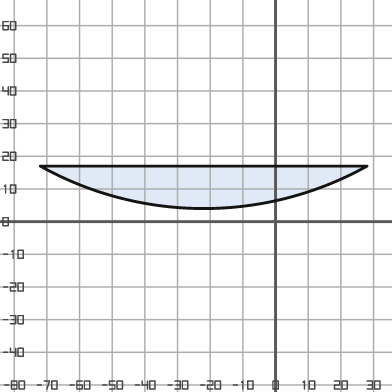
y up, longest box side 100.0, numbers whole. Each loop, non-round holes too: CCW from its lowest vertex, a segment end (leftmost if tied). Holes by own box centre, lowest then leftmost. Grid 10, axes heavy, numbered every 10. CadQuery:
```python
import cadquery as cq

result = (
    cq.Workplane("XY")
    .moveTo(-72.0, 17.0)
    .threePointArc((-22.0, 4.0), (28.0, 17.0))
    .close()
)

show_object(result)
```